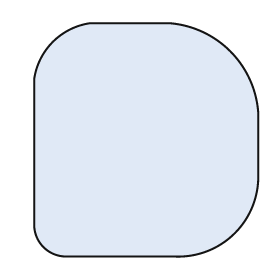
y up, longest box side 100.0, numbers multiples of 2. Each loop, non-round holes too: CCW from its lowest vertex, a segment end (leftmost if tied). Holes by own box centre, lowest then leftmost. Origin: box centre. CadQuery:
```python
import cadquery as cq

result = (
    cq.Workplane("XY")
    .moveTo(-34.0, -50.0)
    .lineTo(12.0, -50.0)
    .threePointArc((38.0, -40.0), (48.0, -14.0))
    .lineTo(48.0, 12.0)
    .threePointArc((36.0, 38.0), (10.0, 50.0))
    .lineTo(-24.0, 50.0)
    .threePointArc((-40.0, 42.0), (-48.0, 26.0))
    .lineTo(-48.0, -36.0)
    .threePointArc((-44.0, -46.0), (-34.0, -50.0))
    .close()
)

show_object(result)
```